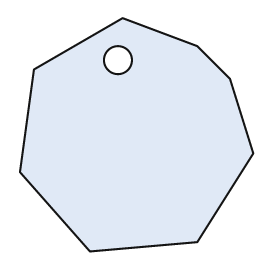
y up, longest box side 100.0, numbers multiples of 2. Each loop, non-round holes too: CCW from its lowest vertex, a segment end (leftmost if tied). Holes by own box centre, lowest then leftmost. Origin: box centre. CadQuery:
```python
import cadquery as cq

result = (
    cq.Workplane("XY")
    .moveTo(-20.0, -50.0)
    .lineTo(26.0, -46.0)
    .lineTo(50.0, -8.0)
    .lineTo(40.0, 24.0)
    .lineTo(26.0, 38.0)
    .lineTo(-6.0, 50.0)
    .lineTo(-44.0, 28.0)
    .lineTo(-50.0, -16.0)
    .close()
    .moveTo(-8.0, 32.0)
    .circle(6.0)
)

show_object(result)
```